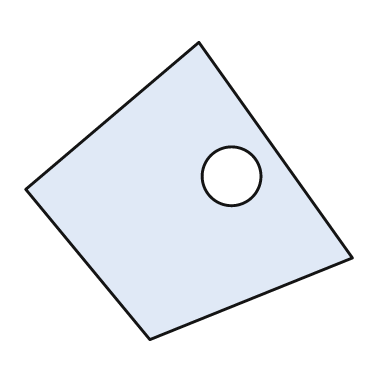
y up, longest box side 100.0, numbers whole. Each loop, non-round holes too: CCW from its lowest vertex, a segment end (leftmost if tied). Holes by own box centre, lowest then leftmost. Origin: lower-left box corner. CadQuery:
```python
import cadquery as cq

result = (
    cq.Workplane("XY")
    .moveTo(38.0, 0.0)
    .lineTo(100.0, 25.0)
    .lineTo(53.0, 91.0)
    .lineTo(0.0, 46.0)
    .close()
    .moveTo(63.0, 50.0)
    .circle(9.0)
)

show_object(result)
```